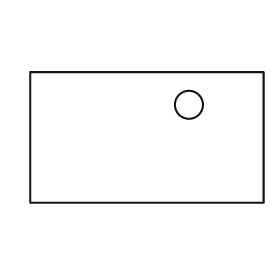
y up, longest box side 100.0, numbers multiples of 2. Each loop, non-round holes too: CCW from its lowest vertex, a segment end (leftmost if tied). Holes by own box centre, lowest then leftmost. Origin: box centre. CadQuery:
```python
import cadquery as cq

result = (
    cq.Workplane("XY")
    .moveTo(-50.0, -28.0)
    .lineTo(50.0, -28.0)
    .lineTo(50.0, 28.0)
    .lineTo(-50.0, 28.0)
    .close()
    .moveTo(18.0, 14.0)
    .circle(6.0)
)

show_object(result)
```